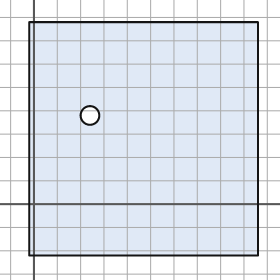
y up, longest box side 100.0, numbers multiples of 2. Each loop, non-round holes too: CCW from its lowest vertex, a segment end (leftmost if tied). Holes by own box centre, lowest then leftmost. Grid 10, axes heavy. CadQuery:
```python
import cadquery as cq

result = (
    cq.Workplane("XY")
    .moveTo(-2.0, -22.0)
    .lineTo(96.0, -22.0)
    .lineTo(96.0, 78.0)
    .lineTo(-2.0, 78.0)
    .close()
    .moveTo(24.0, 38.0)
    .circle(4.0)
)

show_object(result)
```